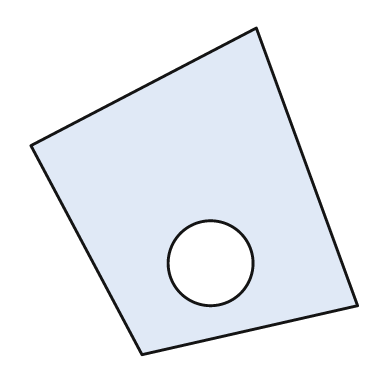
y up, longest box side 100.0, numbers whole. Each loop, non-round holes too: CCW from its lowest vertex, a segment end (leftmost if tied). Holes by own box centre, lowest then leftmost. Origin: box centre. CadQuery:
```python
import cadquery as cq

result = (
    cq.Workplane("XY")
    .moveTo(-16.0, -50.0)
    .lineTo(50.0, -35.0)
    .lineTo(19.0, 50.0)
    .lineTo(-50.0, 14.0)
    .close()
    .moveTo(5.0, -22.0)
    .circle(13.0)
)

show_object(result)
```